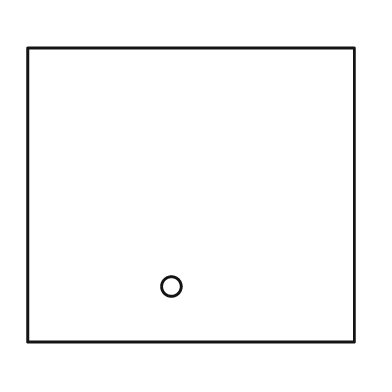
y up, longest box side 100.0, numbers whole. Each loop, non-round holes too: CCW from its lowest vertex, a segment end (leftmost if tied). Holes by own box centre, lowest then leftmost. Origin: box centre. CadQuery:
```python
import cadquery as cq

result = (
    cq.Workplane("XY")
    .moveTo(-50.0, -45.0)
    .lineTo(50.0, -45.0)
    .lineTo(50.0, 45.0)
    .lineTo(-50.0, 45.0)
    .close()
    .moveTo(-6.0, -28.0)
    .circle(3.0)
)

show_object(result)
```